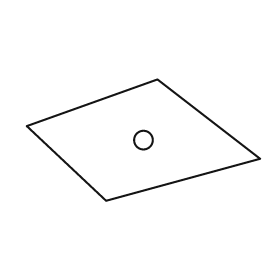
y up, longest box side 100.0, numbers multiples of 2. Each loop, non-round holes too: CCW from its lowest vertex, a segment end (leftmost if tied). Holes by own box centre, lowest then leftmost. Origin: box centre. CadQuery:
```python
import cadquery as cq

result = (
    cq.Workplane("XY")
    .moveTo(-16.0, -26.0)
    .lineTo(50.0, -8.0)
    .lineTo(6.0, 26.0)
    .lineTo(-50.0, 6.0)
    .close()
    .moveTo(0.0, 0.0)
    .circle(4.0)
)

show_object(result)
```